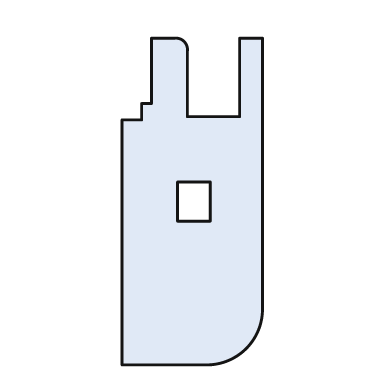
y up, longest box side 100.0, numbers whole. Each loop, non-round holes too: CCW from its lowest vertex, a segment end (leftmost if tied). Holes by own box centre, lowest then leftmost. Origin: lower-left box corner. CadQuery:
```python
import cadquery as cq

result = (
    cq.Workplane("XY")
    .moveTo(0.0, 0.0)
    .lineTo(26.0, 0.0)
    .threePointArc((38.0, 5.0), (43.0, 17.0))
    .lineTo(43.0, 100.0)
    .lineTo(36.0, 100.0)
    .lineTo(36.0, 76.0)
    .lineTo(20.0, 76.0)
    .lineTo(20.0, 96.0)
    .threePointArc((19.0, 99.0), (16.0, 100.0))
    .lineTo(9.0, 100.0)
    .lineTo(9.0, 80.0)
    .lineTo(6.0, 80.0)
    .lineTo(6.0, 75.0)
    .lineTo(0.0, 75.0)
    .close()
    .moveTo(17.0, 44.0)
    .lineTo(27.0, 44.0)
    .lineTo(27.0, 56.0)
    .lineTo(17.0, 56.0)
    .close()
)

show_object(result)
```